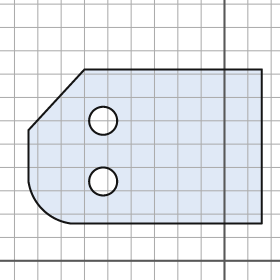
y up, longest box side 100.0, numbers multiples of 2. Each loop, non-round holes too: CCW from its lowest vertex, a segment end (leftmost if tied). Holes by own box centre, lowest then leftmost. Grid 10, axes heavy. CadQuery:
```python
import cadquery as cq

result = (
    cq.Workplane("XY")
    .moveTo(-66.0, 16.0)
    .lineTo(16.0, 16.0)
    .lineTo(16.0, 82.0)
    .lineTo(-60.0, 82.0)
    .lineTo(-84.0, 56.0)
    .lineTo(-84.0, 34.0)
    .threePointArc((-78.0, 22.0), (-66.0, 16.0))
    .close()
    .moveTo(-52.0, 34.0)
    .circle(6.0)
    .moveTo(-52.0, 60.0)
    .circle(6.0)
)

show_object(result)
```